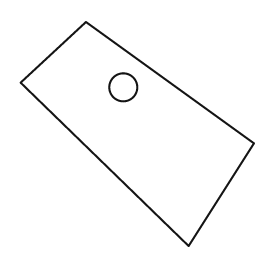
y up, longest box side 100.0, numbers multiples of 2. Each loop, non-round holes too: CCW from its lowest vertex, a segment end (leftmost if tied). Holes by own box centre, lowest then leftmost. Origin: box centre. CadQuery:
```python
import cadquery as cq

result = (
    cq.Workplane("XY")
    .moveTo(22.0, -48.0)
    .lineTo(50.0, -4.0)
    .lineTo(-22.0, 48.0)
    .lineTo(-50.0, 22.0)
    .close()
    .moveTo(-6.0, 20.0)
    .circle(6.0)
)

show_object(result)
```